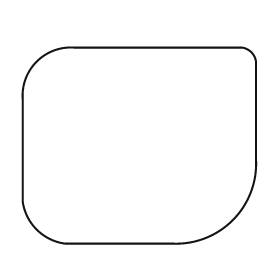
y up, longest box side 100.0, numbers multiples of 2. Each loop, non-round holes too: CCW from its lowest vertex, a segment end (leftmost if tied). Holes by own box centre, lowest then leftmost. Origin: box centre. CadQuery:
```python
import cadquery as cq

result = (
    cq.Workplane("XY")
    .moveTo(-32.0, -42.0)
    .lineTo(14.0, -42.0)
    .threePointArc((40.0, -32.0), (50.0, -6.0))
    .lineTo(50.0, 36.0)
    .threePointArc((48.0, 40.0), (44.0, 42.0))
    .lineTo(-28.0, 42.0)
    .threePointArc((-44.0, 36.0), (-50.0, 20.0))
    .lineTo(-50.0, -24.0)
    .threePointArc((-44.0, -36.0), (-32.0, -42.0))
    .close()
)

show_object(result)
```